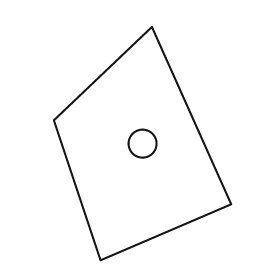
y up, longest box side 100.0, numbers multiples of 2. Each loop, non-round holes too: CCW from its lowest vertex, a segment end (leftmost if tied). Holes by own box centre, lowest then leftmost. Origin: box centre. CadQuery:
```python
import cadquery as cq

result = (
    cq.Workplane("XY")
    .moveTo(-18.0, -50.0)
    .lineTo(38.0, -26.0)
    .lineTo(4.0, 50.0)
    .lineTo(-38.0, 10.0)
    .close()
    .moveTo(0.0, 0.0)
    .circle(6.0)
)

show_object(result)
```